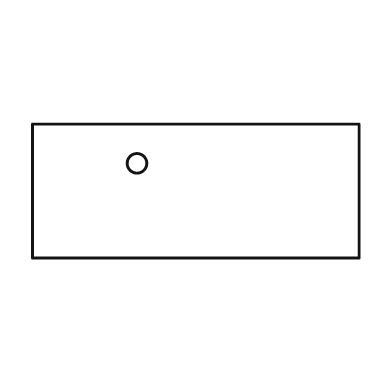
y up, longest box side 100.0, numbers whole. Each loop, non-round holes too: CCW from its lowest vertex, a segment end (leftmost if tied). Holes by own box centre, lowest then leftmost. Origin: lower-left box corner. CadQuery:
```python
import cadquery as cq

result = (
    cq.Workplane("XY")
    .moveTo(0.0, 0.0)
    .lineTo(100.0, 0.0)
    .lineTo(100.0, 41.0)
    .lineTo(0.0, 41.0)
    .close()
    .moveTo(32.0, 29.0)
    .circle(3.0)
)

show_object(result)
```